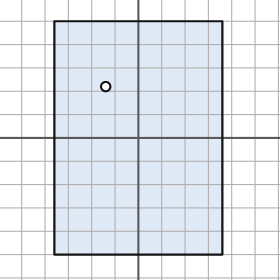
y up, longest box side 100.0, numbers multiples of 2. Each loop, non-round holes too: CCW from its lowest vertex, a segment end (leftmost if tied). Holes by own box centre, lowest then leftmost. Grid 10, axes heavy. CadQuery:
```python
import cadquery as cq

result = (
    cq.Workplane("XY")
    .moveTo(-36.0, -50.0)
    .lineTo(36.0, -50.0)
    .lineTo(36.0, 50.0)
    .lineTo(-36.0, 50.0)
    .close()
    .moveTo(-14.0, 22.0)
    .circle(2.0)
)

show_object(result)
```